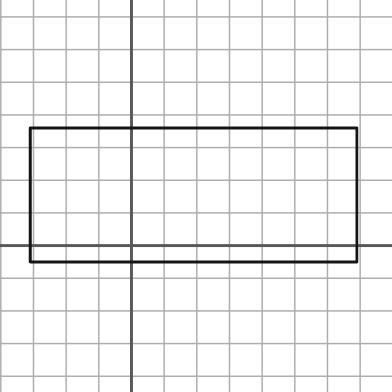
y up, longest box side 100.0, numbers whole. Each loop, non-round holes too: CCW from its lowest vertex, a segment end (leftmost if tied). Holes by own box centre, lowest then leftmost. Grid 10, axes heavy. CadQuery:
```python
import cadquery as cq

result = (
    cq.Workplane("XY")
    .moveTo(-31.0, -5.0)
    .lineTo(69.0, -5.0)
    .lineTo(69.0, 36.0)
    .lineTo(-31.0, 36.0)
    .close()
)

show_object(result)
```